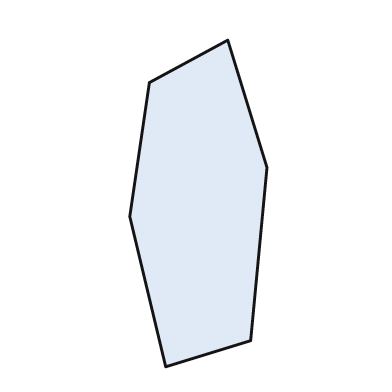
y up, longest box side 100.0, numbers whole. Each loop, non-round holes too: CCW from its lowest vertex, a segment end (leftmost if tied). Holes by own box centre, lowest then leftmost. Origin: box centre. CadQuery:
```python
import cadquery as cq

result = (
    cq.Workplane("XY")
    .moveTo(-10.0, -50.0)
    .lineTo(16.0, -42.0)
    .lineTo(21.0, 11.0)
    .lineTo(9.0, 50.0)
    .lineTo(-15.0, 37.0)
    .lineTo(-21.0, -4.0)
    .close()
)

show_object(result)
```